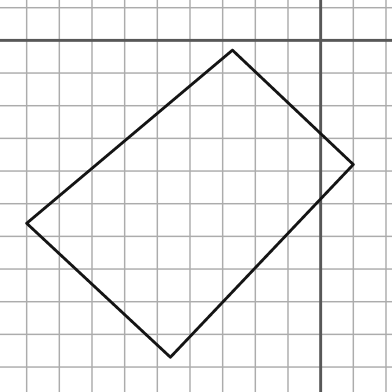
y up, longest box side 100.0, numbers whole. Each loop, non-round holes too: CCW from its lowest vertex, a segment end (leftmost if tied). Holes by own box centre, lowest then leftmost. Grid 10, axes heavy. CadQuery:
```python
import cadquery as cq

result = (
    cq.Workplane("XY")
    .moveTo(-46.0, -97.0)
    .lineTo(10.0, -38.0)
    .lineTo(-27.0, -3.0)
    .lineTo(-90.0, -56.0)
    .close()
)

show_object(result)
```